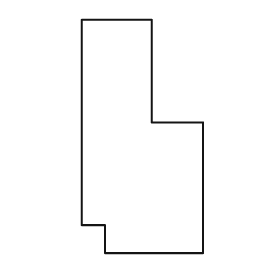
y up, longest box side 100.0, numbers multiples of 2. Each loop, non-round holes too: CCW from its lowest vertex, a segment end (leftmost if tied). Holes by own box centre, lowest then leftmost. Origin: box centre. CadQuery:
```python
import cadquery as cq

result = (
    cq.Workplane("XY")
    .moveTo(-16.0, -50.0)
    .lineTo(26.0, -50.0)
    .lineTo(26.0, 6.0)
    .lineTo(4.0, 6.0)
    .lineTo(4.0, 50.0)
    .lineTo(-26.0, 50.0)
    .lineTo(-26.0, -38.0)
    .lineTo(-16.0, -38.0)
    .close()
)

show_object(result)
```